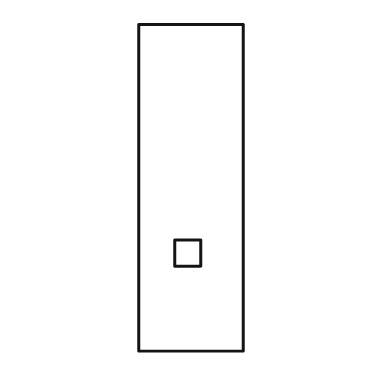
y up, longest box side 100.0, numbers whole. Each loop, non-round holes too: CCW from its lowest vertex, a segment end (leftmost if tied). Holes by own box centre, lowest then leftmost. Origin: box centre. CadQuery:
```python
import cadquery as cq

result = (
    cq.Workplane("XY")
    .moveTo(-16.0, -50.0)
    .lineTo(16.0, -50.0)
    .lineTo(16.0, 50.0)
    .lineTo(-16.0, 50.0)
    .close()
    .moveTo(-5.0, -24.0)
    .lineTo(3.0, -24.0)
    .lineTo(3.0, -16.0)
    .lineTo(-5.0, -16.0)
    .close()
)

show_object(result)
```